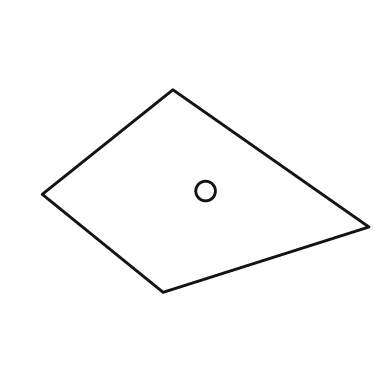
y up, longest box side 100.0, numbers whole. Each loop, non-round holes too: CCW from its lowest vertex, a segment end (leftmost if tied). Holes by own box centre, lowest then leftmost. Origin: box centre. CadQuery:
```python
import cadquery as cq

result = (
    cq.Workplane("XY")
    .moveTo(-13.0, -31.0)
    .lineTo(50.0, -11.0)
    .lineTo(-10.0, 31.0)
    .lineTo(-50.0, -1.0)
    .close()
    .moveTo(0.0, 0.0)
    .circle(3.0)
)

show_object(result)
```